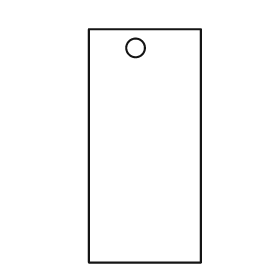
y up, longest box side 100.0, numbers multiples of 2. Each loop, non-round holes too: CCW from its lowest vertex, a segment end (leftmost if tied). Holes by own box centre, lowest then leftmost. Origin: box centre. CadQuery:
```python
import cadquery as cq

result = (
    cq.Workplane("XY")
    .moveTo(-24.0, -50.0)
    .lineTo(24.0, -50.0)
    .lineTo(24.0, 50.0)
    .lineTo(-24.0, 50.0)
    .close()
    .moveTo(-4.0, 42.0)
    .circle(4.0)
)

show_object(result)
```